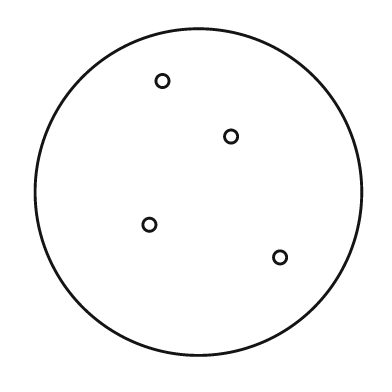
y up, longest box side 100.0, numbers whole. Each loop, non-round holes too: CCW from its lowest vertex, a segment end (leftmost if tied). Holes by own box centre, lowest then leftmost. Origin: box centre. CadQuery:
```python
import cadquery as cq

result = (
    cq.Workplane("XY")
    .moveTo(0.0, 0.0)
    .circle(50.0)
    .moveTo(25.0, -20.0)
    .circle(2.0)
    .moveTo(-15.0, -10.0)
    .circle(2.0)
    .moveTo(10.0, 17.0)
    .circle(2.0)
    .moveTo(-11.0, 34.0)
    .circle(2.0)
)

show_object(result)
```